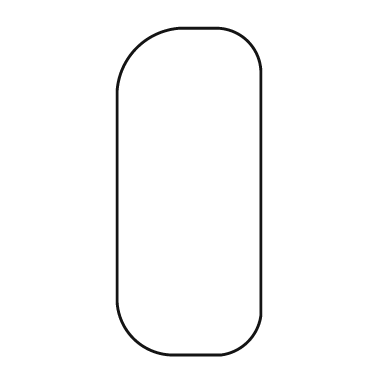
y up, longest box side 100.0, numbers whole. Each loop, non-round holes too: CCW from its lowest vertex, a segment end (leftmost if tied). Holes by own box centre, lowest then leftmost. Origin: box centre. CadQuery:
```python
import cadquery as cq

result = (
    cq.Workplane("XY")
    .moveTo(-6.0, -50.0)
    .lineTo(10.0, -50.0)
    .threePointArc((18.0, -46.0), (22.0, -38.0))
    .lineTo(22.0, 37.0)
    .threePointArc((18.0, 46.0), (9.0, 50.0))
    .lineTo(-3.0, 50.0)
    .threePointArc((-16.0, 44.0), (-22.0, 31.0))
    .lineTo(-22.0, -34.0)
    .threePointArc((-17.0, -45.0), (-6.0, -50.0))
    .close()
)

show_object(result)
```